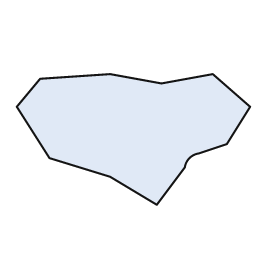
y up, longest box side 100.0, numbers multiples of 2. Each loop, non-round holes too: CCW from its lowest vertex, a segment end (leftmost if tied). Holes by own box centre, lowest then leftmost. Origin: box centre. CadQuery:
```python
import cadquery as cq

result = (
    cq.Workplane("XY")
    .moveTo(10.0, -28.0)
    .lineTo(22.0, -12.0)
    .threePointArc((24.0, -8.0), (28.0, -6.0))
    .lineTo(40.0, -2.0)
    .lineTo(50.0, 14.0)
    .lineTo(34.0, 28.0)
    .lineTo(12.0, 24.0)
    .lineTo(-10.0, 28.0)
    .lineTo(-40.0, 26.0)
    .lineTo(-50.0, 14.0)
    .lineTo(-36.0, -8.0)
    .lineTo(-10.0, -16.0)
    .close()
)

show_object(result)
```